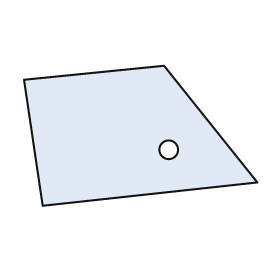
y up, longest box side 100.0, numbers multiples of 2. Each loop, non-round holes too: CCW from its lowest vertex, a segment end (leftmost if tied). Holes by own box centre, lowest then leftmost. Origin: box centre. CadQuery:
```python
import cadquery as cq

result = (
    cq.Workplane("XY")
    .moveTo(-42.0, -30.0)
    .lineTo(50.0, -20.0)
    .lineTo(10.0, 30.0)
    .lineTo(-50.0, 24.0)
    .close()
    .moveTo(12.0, -6.0)
    .circle(4.0)
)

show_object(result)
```